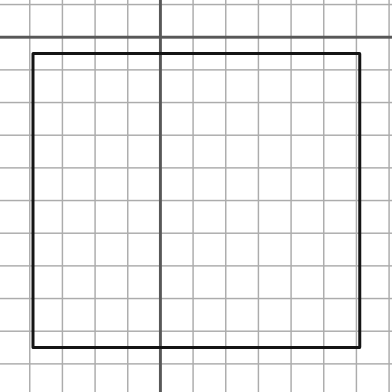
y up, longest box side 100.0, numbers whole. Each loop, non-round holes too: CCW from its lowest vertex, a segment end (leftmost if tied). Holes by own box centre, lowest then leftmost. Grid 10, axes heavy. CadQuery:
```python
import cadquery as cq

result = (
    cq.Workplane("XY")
    .moveTo(-39.0, -95.0)
    .lineTo(61.0, -95.0)
    .lineTo(61.0, -5.0)
    .lineTo(-39.0, -5.0)
    .close()
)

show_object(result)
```